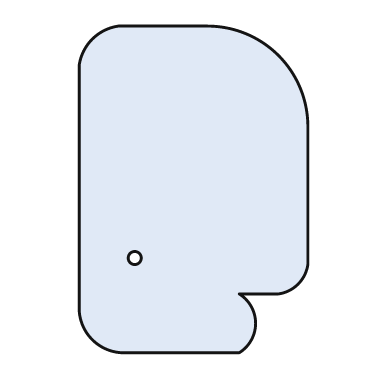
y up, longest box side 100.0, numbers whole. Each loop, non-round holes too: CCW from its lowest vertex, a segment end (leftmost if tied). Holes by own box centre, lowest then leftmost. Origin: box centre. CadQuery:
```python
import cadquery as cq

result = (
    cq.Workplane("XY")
    .moveTo(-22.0, -50.0)
    .lineTo(14.0, -50.0)
    .threePointArc((19.0, -41.0), (14.0, -32.0))
    .lineTo(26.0, -32.0)
    .threePointArc((32.0, -29.0), (35.0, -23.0))
    .lineTo(35.0, 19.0)
    .threePointArc((26.0, 41.0), (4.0, 50.0))
    .lineTo(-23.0, 50.0)
    .threePointArc((-31.0, 46.0), (-35.0, 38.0))
    .lineTo(-35.0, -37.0)
    .threePointArc((-31.0, -46.0), (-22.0, -50.0))
    .close()
    .moveTo(-18.0, -21.0)
    .circle(2.0)
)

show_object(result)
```